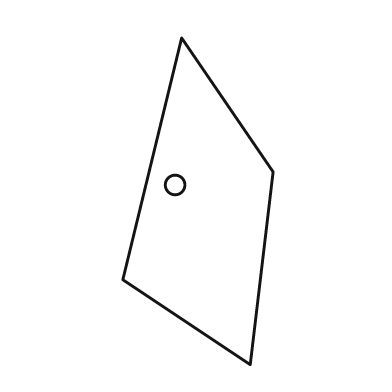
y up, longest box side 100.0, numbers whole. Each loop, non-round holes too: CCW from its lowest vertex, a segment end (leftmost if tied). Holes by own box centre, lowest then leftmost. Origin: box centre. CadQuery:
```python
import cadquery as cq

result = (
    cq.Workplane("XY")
    .moveTo(16.0, -50.0)
    .lineTo(23.0, 9.0)
    .lineTo(-5.0, 50.0)
    .lineTo(-23.0, -24.0)
    .close()
    .moveTo(-7.0, 5.0)
    .circle(3.0)
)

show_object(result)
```